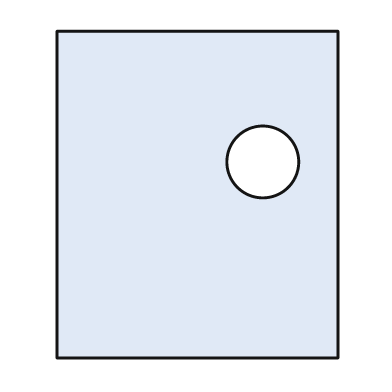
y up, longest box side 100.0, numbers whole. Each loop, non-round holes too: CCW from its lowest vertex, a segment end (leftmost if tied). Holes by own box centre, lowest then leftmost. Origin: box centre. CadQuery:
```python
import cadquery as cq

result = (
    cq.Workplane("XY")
    .moveTo(-43.0, -50.0)
    .lineTo(43.0, -50.0)
    .lineTo(43.0, 50.0)
    .lineTo(-43.0, 50.0)
    .close()
    .moveTo(20.0, 10.0)
    .circle(11.0)
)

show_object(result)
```